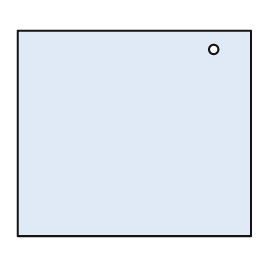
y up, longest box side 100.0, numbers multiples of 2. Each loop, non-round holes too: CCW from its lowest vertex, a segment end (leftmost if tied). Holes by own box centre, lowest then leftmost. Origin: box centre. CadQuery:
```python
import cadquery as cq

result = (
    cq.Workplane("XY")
    .moveTo(-50.0, -44.0)
    .lineTo(50.0, -44.0)
    .lineTo(50.0, 44.0)
    .lineTo(-50.0, 44.0)
    .close()
    .moveTo(34.0, 36.0)
    .circle(2.0)
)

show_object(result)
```